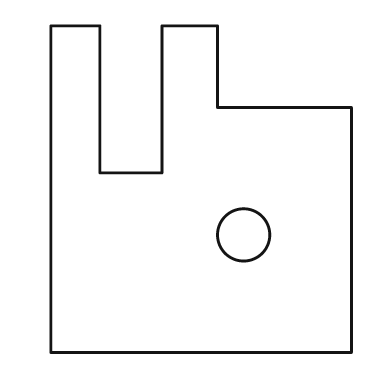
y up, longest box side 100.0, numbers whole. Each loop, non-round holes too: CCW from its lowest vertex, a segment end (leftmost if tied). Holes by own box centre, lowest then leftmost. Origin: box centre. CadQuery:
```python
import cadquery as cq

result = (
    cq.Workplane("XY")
    .moveTo(-46.0, -50.0)
    .lineTo(46.0, -50.0)
    .lineTo(46.0, 25.0)
    .lineTo(5.0, 25.0)
    .lineTo(5.0, 50.0)
    .lineTo(-12.0, 50.0)
    .lineTo(-12.0, 5.0)
    .lineTo(-31.0, 5.0)
    .lineTo(-31.0, 50.0)
    .lineTo(-46.0, 50.0)
    .close()
    .moveTo(13.0, -14.0)
    .circle(8.0)
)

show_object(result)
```